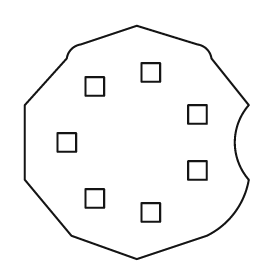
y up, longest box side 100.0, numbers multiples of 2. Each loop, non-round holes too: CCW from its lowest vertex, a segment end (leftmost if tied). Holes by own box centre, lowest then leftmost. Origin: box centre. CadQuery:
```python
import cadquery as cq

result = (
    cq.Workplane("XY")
    .moveTo(0.0, -50.0)
    .lineTo(30.0, -40.0)
    .threePointArc((42.0, -30.0), (48.0, -16.0))
    .threePointArc((42.0, 0.0), (48.0, 16.0))
    .lineTo(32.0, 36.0)
    .threePointArc((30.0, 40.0), (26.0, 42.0))
    .lineTo(0.0, 50.0)
    .lineTo(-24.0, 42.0)
    .threePointArc((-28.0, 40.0), (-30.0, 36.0))
    .lineTo(-48.0, 16.0)
    .lineTo(-48.0, -16.0)
    .lineTo(-28.0, -40.0)
    .close()
    .moveTo(2.0, -34.0)
    .lineTo(10.0, -34.0)
    .lineTo(10.0, -26.0)
    .lineTo(2.0, -26.0)
    .close()
    .moveTo(-22.0, -28.0)
    .lineTo(-14.0, -28.0)
    .lineTo(-14.0, -20.0)
    .lineTo(-22.0, -20.0)
    .close()
    .moveTo(22.0, -16.0)
    .lineTo(30.0, -16.0)
    .lineTo(30.0, -8.0)
    .lineTo(22.0, -8.0)
    .close()
    .moveTo(-34.0, -4.0)
    .lineTo(-26.0, -4.0)
    .lineTo(-26.0, 4.0)
    .lineTo(-34.0, 4.0)
    .close()
    .moveTo(22.0, 8.0)
    .lineTo(30.0, 8.0)
    .lineTo(30.0, 16.0)
    .lineTo(22.0, 16.0)
    .close()
    .moveTo(-22.0, 20.0)
    .lineTo(-14.0, 20.0)
    .lineTo(-14.0, 28.0)
    .lineTo(-22.0, 28.0)
    .close()
    .moveTo(2.0, 26.0)
    .lineTo(10.0, 26.0)
    .lineTo(10.0, 34.0)
    .lineTo(2.0, 34.0)
    .close()
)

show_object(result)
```